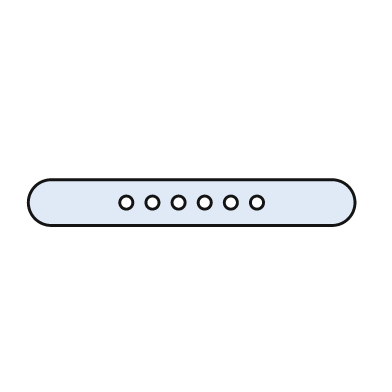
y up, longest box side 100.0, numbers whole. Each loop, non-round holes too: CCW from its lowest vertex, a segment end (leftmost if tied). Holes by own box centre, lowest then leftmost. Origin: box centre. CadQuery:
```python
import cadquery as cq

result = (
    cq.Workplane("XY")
    .moveTo(-43.0, -7.0)
    .lineTo(43.0, -7.0)
    .threePointArc((50.0, 0.0), (43.0, 7.0))
    .lineTo(-43.0, 7.0)
    .threePointArc((-50.0, 0.0), (-43.0, -7.0))
    .close()
    .moveTo(-20.0, 0.0)
    .circle(2.0)
    .moveTo(-12.0, 0.0)
    .circle(2.0)
    .moveTo(-4.0, 0.0)
    .circle(2.0)
    .moveTo(4.0, 0.0)
    .circle(2.0)
    .moveTo(12.0, 0.0)
    .circle(2.0)
    .moveTo(20.0, 0.0)
    .circle(2.0)
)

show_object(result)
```